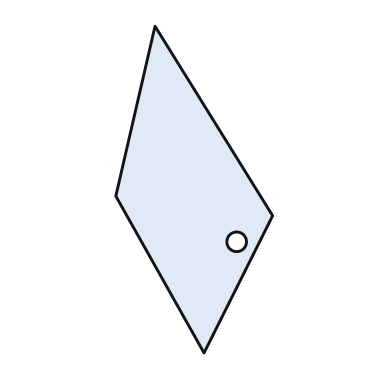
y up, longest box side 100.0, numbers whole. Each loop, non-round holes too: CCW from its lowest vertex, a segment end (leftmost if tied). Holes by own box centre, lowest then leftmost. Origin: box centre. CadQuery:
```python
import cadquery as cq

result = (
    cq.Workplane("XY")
    .moveTo(3.0, -50.0)
    .lineTo(24.0, -8.0)
    .lineTo(-12.0, 50.0)
    .lineTo(-24.0, -2.0)
    .close()
    .moveTo(13.0, -16.0)
    .circle(3.0)
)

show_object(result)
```